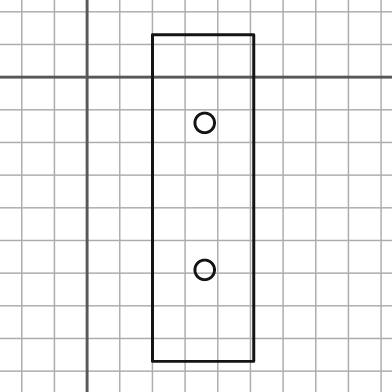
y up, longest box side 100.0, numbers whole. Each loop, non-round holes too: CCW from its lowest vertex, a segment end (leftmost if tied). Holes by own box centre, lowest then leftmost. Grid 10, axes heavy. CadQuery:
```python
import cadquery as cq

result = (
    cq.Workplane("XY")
    .moveTo(20.0, -87.0)
    .lineTo(51.0, -87.0)
    .lineTo(51.0, 13.0)
    .lineTo(20.0, 13.0)
    .close()
    .moveTo(36.0, -59.0)
    .circle(3.0)
    .moveTo(36.0, -14.0)
    .circle(3.0)
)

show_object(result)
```